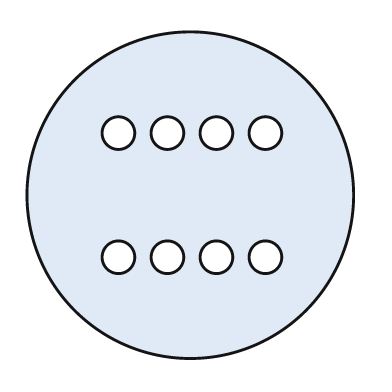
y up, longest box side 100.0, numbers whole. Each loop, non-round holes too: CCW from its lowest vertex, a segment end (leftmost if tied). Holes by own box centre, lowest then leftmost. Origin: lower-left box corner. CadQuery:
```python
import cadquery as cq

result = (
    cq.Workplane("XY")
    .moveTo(50.0, 50.0)
    .circle(50.0)
    .moveTo(28.0, 31.0)
    .circle(5.0)
    .moveTo(43.0, 31.0)
    .circle(5.0)
    .moveTo(58.0, 31.0)
    .circle(5.0)
    .moveTo(73.0, 31.0)
    .circle(5.0)
    .moveTo(28.0, 69.0)
    .circle(5.0)
    .moveTo(43.0, 69.0)
    .circle(5.0)
    .moveTo(58.0, 69.0)
    .circle(5.0)
    .moveTo(73.0, 69.0)
    .circle(5.0)
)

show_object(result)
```